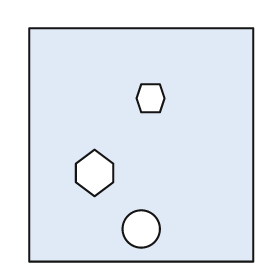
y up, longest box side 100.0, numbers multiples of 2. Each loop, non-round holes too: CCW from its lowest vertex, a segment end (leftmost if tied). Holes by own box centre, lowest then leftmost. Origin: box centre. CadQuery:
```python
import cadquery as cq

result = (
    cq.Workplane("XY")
    .moveTo(-48.0, -50.0)
    .lineTo(48.0, -50.0)
    .lineTo(48.0, 50.0)
    .lineTo(-48.0, 50.0)
    .close()
    .moveTo(0.0, -36.0)
    .circle(8.0)
    .moveTo(-20.0, -22.0)
    .lineTo(-12.0, -16.0)
    .lineTo(-12.0, -8.0)
    .lineTo(-20.0, -2.0)
    .lineTo(-28.0, -8.0)
    .lineTo(-28.0, -16.0)
    .close()
    .moveTo(0.0, 14.0)
    .lineTo(8.0, 14.0)
    .lineTo(10.0, 20.0)
    .lineTo(8.0, 26.0)
    .lineTo(0.0, 26.0)
    .lineTo(-2.0, 20.0)
    .close()
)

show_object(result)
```